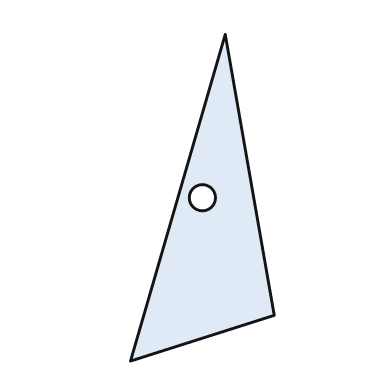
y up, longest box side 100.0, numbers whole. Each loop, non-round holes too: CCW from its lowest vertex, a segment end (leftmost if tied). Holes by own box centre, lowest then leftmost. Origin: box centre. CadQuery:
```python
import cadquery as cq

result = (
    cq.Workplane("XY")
    .moveTo(-22.0, -50.0)
    .lineTo(22.0, -36.0)
    .lineTo(7.0, 50.0)
    .close()
    .moveTo(0.0, 0.0)
    .circle(4.0)
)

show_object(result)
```